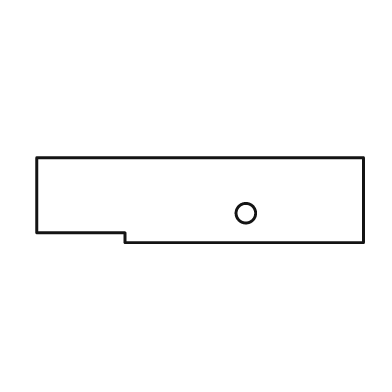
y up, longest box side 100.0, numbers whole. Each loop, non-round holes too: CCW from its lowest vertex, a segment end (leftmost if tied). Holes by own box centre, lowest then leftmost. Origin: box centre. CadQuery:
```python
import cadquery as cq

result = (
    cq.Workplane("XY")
    .moveTo(-23.0, -13.0)
    .lineTo(50.0, -13.0)
    .lineTo(50.0, 13.0)
    .lineTo(-50.0, 13.0)
    .lineTo(-50.0, -10.0)
    .lineTo(-23.0, -10.0)
    .close()
    .moveTo(14.0, -4.0)
    .circle(3.0)
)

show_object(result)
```